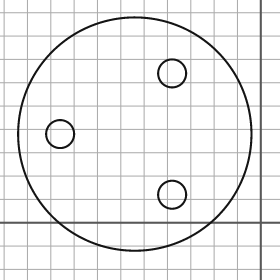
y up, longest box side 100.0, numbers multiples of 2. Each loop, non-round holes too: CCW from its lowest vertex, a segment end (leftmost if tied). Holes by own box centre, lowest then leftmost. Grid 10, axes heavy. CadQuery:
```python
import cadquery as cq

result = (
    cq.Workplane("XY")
    .moveTo(-54.0, 38.0)
    .circle(50.0)
    .moveTo(-38.0, 12.0)
    .circle(6.0)
    .moveTo(-86.0, 38.0)
    .circle(6.0)
    .moveTo(-38.0, 64.0)
    .circle(6.0)
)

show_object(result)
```